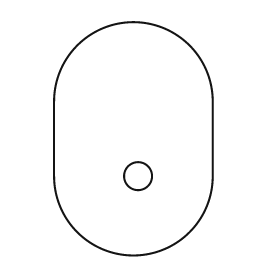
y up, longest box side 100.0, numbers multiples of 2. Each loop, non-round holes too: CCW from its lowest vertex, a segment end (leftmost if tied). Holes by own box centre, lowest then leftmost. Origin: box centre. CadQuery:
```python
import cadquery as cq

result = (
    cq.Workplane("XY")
    .moveTo(-34.0, -16.0)
    .threePointArc((0.0, -50.0), (34.0, -16.0))
    .lineTo(34.0, 16.0)
    .threePointArc((0.0, 50.0), (-34.0, 16.0))
    .close()
    .moveTo(2.0, -16.0)
    .circle(6.0)
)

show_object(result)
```